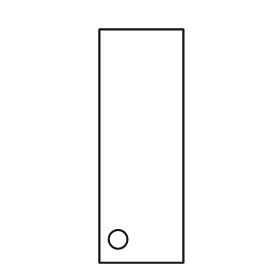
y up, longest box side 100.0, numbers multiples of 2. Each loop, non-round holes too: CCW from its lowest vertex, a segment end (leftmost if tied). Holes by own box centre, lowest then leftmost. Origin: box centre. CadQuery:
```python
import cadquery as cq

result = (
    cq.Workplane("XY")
    .moveTo(-18.0, -50.0)
    .lineTo(18.0, -50.0)
    .lineTo(18.0, 50.0)
    .lineTo(-18.0, 50.0)
    .close()
    .moveTo(-10.0, -40.0)
    .circle(4.0)
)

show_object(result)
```